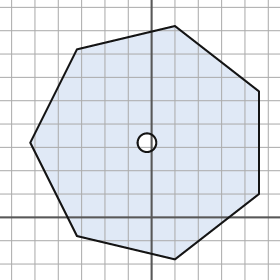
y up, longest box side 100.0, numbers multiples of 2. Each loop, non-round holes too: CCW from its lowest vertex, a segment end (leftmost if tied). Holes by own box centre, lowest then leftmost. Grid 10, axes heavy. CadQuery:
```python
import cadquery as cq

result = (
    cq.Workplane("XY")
    .moveTo(10.0, -18.0)
    .lineTo(46.0, 10.0)
    .lineTo(46.0, 54.0)
    .lineTo(10.0, 82.0)
    .lineTo(-32.0, 72.0)
    .lineTo(-52.0, 32.0)
    .lineTo(-32.0, -8.0)
    .close()
    .moveTo(-2.0, 32.0)
    .circle(4.0)
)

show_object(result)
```